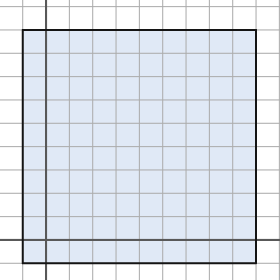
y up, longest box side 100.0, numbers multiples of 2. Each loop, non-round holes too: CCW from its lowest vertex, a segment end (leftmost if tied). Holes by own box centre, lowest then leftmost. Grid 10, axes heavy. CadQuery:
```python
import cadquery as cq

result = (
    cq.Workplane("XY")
    .moveTo(-10.0, -10.0)
    .lineTo(90.0, -10.0)
    .lineTo(90.0, 90.0)
    .lineTo(-10.0, 90.0)
    .close()
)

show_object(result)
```